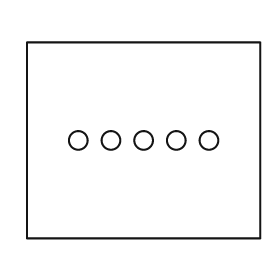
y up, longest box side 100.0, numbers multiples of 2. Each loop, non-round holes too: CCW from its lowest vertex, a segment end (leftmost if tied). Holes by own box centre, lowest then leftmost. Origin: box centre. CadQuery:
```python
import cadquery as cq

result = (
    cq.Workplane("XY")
    .moveTo(-50.0, -42.0)
    .lineTo(50.0, -42.0)
    .lineTo(50.0, 42.0)
    .lineTo(-50.0, 42.0)
    .close()
    .moveTo(-28.0, 0.0)
    .circle(4.0)
    .moveTo(-14.0, 0.0)
    .circle(4.0)
    .moveTo(0.0, 0.0)
    .circle(4.0)
    .moveTo(14.0, 0.0)
    .circle(4.0)
    .moveTo(28.0, 0.0)
    .circle(4.0)
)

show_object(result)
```